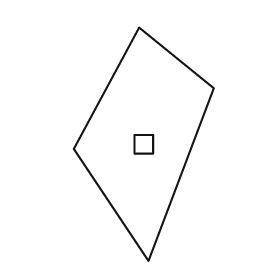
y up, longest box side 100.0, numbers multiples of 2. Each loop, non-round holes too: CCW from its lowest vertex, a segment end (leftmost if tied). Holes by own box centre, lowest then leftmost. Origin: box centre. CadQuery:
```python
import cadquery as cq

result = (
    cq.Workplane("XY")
    .moveTo(2.0, -50.0)
    .lineTo(30.0, 24.0)
    .lineTo(-2.0, 50.0)
    .lineTo(-30.0, -2.0)
    .close()
    .moveTo(-4.0, -4.0)
    .lineTo(4.0, -4.0)
    .lineTo(4.0, 4.0)
    .lineTo(-4.0, 4.0)
    .close()
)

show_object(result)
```